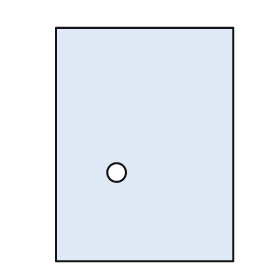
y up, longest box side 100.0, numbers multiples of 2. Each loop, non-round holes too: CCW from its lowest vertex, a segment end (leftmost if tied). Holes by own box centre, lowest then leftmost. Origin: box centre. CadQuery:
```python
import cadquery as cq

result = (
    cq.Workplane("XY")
    .moveTo(-38.0, -50.0)
    .lineTo(38.0, -50.0)
    .lineTo(38.0, 50.0)
    .lineTo(-38.0, 50.0)
    .close()
    .moveTo(-12.0, -12.0)
    .circle(4.0)
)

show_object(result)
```